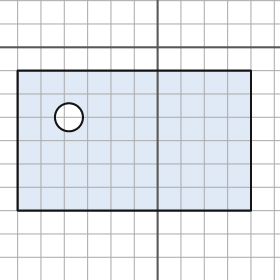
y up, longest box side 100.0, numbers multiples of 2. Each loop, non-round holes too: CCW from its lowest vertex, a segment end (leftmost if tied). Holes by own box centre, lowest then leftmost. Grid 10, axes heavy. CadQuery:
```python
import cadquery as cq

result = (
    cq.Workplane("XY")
    .moveTo(-60.0, -70.0)
    .lineTo(40.0, -70.0)
    .lineTo(40.0, -10.0)
    .lineTo(-60.0, -10.0)
    .close()
    .moveTo(-38.0, -30.0)
    .circle(6.0)
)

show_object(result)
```